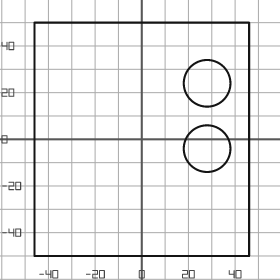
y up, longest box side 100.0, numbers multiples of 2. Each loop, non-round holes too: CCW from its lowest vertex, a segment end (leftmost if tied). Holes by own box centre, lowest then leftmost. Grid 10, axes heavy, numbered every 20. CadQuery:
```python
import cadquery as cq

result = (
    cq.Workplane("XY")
    .moveTo(-46.0, -50.0)
    .lineTo(46.0, -50.0)
    .lineTo(46.0, 50.0)
    .lineTo(-46.0, 50.0)
    .close()
    .moveTo(28.0, -4.0)
    .circle(10.0)
    .moveTo(28.0, 24.0)
    .circle(10.0)
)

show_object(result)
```